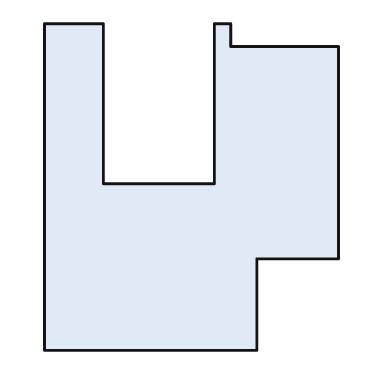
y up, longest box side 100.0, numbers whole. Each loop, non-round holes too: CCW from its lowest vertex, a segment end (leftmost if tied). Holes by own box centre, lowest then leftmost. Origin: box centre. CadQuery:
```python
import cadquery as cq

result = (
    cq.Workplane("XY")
    .moveTo(-45.0, -50.0)
    .lineTo(20.0, -50.0)
    .lineTo(20.0, -22.0)
    .lineTo(45.0, -22.0)
    .lineTo(45.0, 43.0)
    .lineTo(12.0, 43.0)
    .lineTo(12.0, 50.0)
    .lineTo(7.0, 50.0)
    .lineTo(7.0, 1.0)
    .lineTo(-27.0, 1.0)
    .lineTo(-27.0, 50.0)
    .lineTo(-45.0, 50.0)
    .close()
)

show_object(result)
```